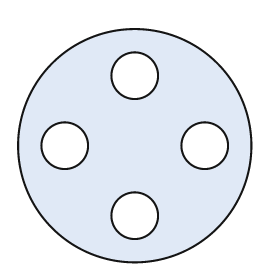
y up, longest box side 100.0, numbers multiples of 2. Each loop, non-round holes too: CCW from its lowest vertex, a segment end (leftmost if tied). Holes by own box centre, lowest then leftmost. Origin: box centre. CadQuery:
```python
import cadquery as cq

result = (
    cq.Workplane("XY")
    .moveTo(0.0, 0.0)
    .circle(50.0)
    .moveTo(0.0, -30.0)
    .circle(10.0)
    .moveTo(-30.0, 0.0)
    .circle(10.0)
    .moveTo(30.0, 0.0)
    .circle(10.0)
    .moveTo(0.0, 30.0)
    .circle(10.0)
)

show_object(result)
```